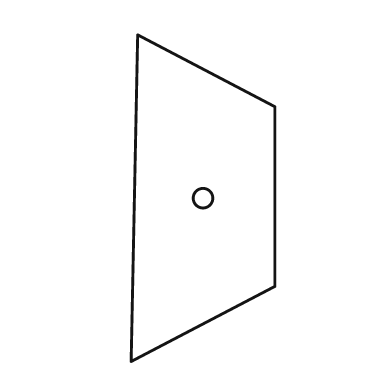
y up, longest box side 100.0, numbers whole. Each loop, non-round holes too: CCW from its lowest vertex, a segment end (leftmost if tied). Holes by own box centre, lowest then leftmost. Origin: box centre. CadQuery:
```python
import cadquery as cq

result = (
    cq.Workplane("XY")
    .moveTo(-22.0, -50.0)
    .lineTo(22.0, -27.0)
    .lineTo(22.0, 28.0)
    .lineTo(-20.0, 50.0)
    .close()
    .moveTo(0.0, 0.0)
    .circle(3.0)
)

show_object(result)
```